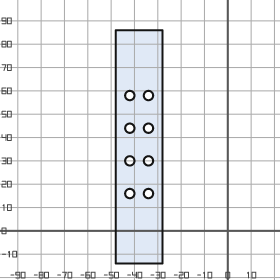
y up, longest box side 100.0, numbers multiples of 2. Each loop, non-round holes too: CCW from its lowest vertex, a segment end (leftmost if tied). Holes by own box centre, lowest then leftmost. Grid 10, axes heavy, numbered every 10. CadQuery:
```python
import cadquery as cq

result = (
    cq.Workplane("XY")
    .moveTo(-48.0, -14.0)
    .lineTo(-28.0, -14.0)
    .lineTo(-28.0, 86.0)
    .lineTo(-48.0, 86.0)
    .close()
    .moveTo(-42.0, 16.0)
    .circle(2.0)
    .moveTo(-34.0, 16.0)
    .circle(2.0)
    .moveTo(-42.0, 30.0)
    .circle(2.0)
    .moveTo(-34.0, 30.0)
    .circle(2.0)
    .moveTo(-42.0, 44.0)
    .circle(2.0)
    .moveTo(-34.0, 44.0)
    .circle(2.0)
    .moveTo(-42.0, 58.0)
    .circle(2.0)
    .moveTo(-34.0, 58.0)
    .circle(2.0)
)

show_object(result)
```